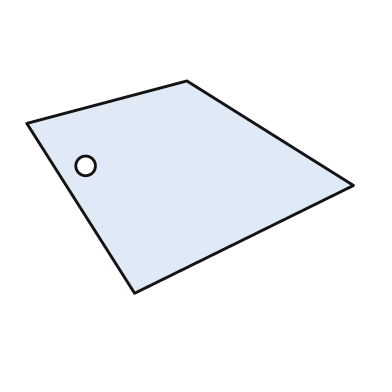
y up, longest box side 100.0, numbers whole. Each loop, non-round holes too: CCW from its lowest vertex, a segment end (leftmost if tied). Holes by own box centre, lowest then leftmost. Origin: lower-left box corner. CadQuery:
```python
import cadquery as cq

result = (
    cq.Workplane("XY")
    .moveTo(33.0, 0.0)
    .lineTo(100.0, 33.0)
    .lineTo(49.0, 65.0)
    .lineTo(0.0, 52.0)
    .close()
    .moveTo(18.0, 39.0)
    .circle(3.0)
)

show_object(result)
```